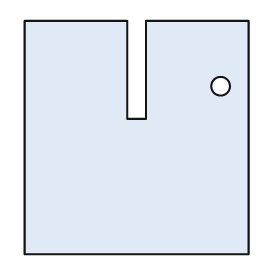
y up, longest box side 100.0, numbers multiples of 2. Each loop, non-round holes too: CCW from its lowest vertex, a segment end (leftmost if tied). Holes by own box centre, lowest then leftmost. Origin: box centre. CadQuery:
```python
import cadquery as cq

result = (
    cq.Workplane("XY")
    .moveTo(-48.0, -50.0)
    .lineTo(48.0, -50.0)
    .lineTo(48.0, 50.0)
    .lineTo(4.0, 50.0)
    .lineTo(4.0, 8.0)
    .lineTo(-4.0, 8.0)
    .lineTo(-4.0, 50.0)
    .lineTo(-48.0, 50.0)
    .close()
    .moveTo(36.0, 22.0)
    .circle(4.0)
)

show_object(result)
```